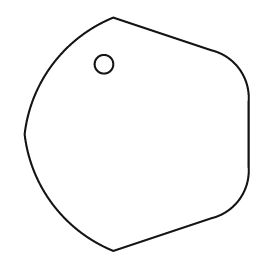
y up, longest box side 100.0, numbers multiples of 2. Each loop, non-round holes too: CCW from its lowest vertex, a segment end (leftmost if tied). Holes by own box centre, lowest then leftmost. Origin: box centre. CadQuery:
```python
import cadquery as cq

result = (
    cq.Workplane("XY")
    .moveTo(-10.0, -50.0)
    .lineTo(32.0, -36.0)
    .threePointArc((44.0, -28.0), (48.0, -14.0))
    .lineTo(48.0, 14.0)
    .threePointArc((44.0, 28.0), (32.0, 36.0))
    .lineTo(-10.0, 50.0)
    .threePointArc((-36.0, 30.0), (-48.0, 0.0))
    .threePointArc((-36.0, -30.0), (-10.0, -50.0))
    .close()
    .moveTo(-14.0, 30.0)
    .circle(4.0)
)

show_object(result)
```